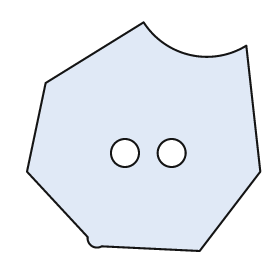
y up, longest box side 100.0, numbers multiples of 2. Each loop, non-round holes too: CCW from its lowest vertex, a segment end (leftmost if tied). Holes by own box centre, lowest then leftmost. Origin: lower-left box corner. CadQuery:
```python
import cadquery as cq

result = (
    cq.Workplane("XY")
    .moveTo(74.0, 0.0)
    .lineTo(100.0, 34.0)
    .lineTo(94.0, 88.0)
    .threePointArc((70.0, 84.0), (50.0, 98.0))
    .lineTo(8.0, 72.0)
    .lineTo(0.0, 34.0)
    .lineTo(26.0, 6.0)
    .threePointArc((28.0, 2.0), (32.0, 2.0))
    .close()
    .moveTo(42.0, 42.0)
    .circle(6.0)
    .moveTo(62.0, 42.0)
    .circle(6.0)
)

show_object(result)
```